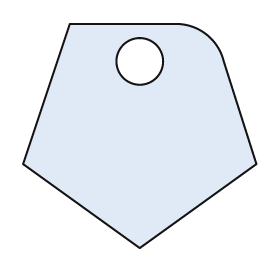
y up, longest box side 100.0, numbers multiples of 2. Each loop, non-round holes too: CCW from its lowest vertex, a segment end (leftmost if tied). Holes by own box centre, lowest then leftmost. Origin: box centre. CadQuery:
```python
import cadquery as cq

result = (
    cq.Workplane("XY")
    .moveTo(0.0, -48.0)
    .lineTo(50.0, -12.0)
    .lineTo(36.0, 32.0)
    .threePointArc((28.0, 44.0), (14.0, 48.0))
    .lineTo(-30.0, 48.0)
    .lineTo(-50.0, -12.0)
    .close()
    .moveTo(0.0, 32.0)
    .circle(10.0)
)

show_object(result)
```